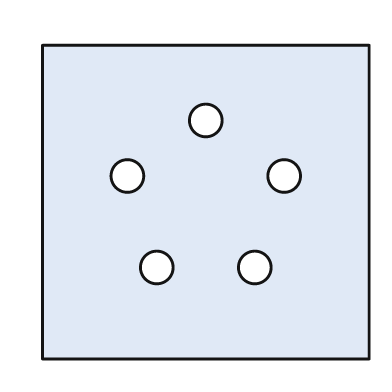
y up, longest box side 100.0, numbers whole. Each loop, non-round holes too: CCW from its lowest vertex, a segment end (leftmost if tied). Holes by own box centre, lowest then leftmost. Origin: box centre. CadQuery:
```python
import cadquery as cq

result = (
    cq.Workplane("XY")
    .moveTo(-50.0, -48.0)
    .lineTo(50.0, -48.0)
    .lineTo(50.0, 48.0)
    .lineTo(-50.0, 48.0)
    .close()
    .moveTo(-15.0, -20.0)
    .circle(5.0)
    .moveTo(15.0, -20.0)
    .circle(5.0)
    .moveTo(-24.0, 8.0)
    .circle(5.0)
    .moveTo(24.0, 8.0)
    .circle(5.0)
    .moveTo(0.0, 25.0)
    .circle(5.0)
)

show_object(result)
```